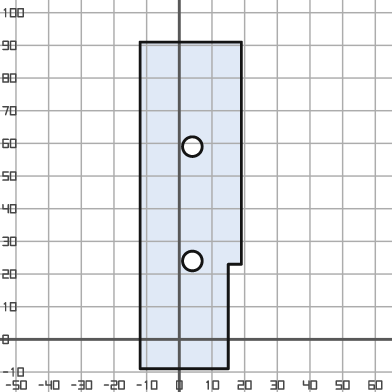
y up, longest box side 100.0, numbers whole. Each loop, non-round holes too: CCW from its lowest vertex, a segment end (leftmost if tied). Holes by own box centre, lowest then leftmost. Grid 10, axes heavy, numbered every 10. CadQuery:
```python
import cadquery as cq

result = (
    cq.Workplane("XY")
    .moveTo(-12.0, -9.0)
    .lineTo(15.0, -9.0)
    .lineTo(15.0, 23.0)
    .lineTo(19.0, 23.0)
    .lineTo(19.0, 91.0)
    .lineTo(-12.0, 91.0)
    .close()
    .moveTo(4.0, 24.0)
    .circle(3.0)
    .moveTo(4.0, 59.0)
    .circle(3.0)
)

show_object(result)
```